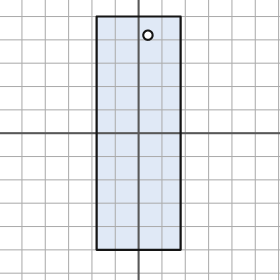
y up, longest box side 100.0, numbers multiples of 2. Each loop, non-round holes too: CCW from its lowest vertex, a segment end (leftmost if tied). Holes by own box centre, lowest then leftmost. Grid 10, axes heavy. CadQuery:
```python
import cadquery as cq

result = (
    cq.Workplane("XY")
    .moveTo(-18.0, -50.0)
    .lineTo(18.0, -50.0)
    .lineTo(18.0, 50.0)
    .lineTo(-18.0, 50.0)
    .close()
    .moveTo(4.0, 42.0)
    .circle(2.0)
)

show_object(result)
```